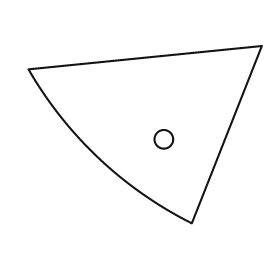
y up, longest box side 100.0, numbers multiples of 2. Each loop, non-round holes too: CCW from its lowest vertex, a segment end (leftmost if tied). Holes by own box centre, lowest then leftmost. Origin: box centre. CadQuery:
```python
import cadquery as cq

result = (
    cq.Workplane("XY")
    .moveTo(20.0, -38.0)
    .lineTo(50.0, 38.0)
    .lineTo(-50.0, 28.0)
    .threePointArc((-20.0, -10.0), (20.0, -38.0))
    .close()
    .moveTo(8.0, -2.0)
    .circle(4.0)
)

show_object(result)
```